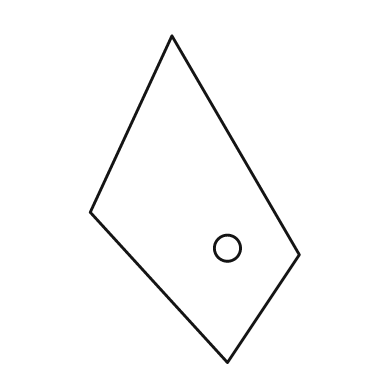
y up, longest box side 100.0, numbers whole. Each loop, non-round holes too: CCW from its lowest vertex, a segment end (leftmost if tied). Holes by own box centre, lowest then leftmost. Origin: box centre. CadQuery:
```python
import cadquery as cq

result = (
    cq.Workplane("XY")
    .moveTo(10.0, -50.0)
    .lineTo(32.0, -17.0)
    .lineTo(-7.0, 50.0)
    .lineTo(-32.0, -4.0)
    .close()
    .moveTo(10.0, -15.0)
    .circle(4.0)
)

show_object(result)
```